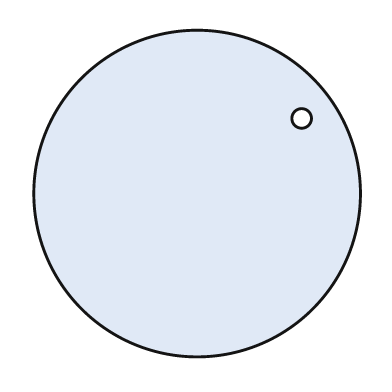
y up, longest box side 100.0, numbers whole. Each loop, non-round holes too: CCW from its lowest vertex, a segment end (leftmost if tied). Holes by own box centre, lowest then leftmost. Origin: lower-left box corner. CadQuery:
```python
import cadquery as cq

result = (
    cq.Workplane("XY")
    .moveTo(50.0, 50.0)
    .circle(50.0)
    .moveTo(82.0, 73.0)
    .circle(3.0)
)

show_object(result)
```